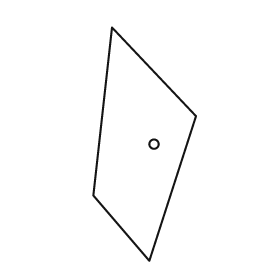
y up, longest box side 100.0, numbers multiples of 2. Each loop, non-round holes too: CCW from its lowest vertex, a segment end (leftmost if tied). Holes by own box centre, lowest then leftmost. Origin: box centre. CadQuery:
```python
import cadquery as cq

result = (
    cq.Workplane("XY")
    .moveTo(2.0, -50.0)
    .lineTo(22.0, 12.0)
    .lineTo(-14.0, 50.0)
    .lineTo(-22.0, -22.0)
    .close()
    .moveTo(4.0, 0.0)
    .circle(2.0)
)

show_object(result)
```